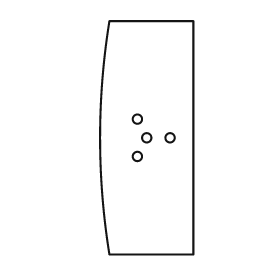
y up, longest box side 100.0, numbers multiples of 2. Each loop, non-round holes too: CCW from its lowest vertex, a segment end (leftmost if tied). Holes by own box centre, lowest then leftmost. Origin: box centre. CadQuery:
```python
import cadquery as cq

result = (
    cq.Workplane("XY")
    .moveTo(-16.0, -50.0)
    .lineTo(20.0, -50.0)
    .lineTo(20.0, 50.0)
    .lineTo(-16.0, 50.0)
    .threePointArc((-20.0, 0.0), (-16.0, -50.0))
    .close()
    .moveTo(-4.0, -8.0)
    .circle(2.0)
    .moveTo(0.0, 0.0)
    .circle(2.0)
    .moveTo(10.0, 0.0)
    .circle(2.0)
    .moveTo(-4.0, 8.0)
    .circle(2.0)
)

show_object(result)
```